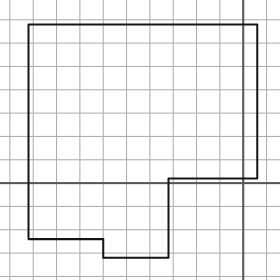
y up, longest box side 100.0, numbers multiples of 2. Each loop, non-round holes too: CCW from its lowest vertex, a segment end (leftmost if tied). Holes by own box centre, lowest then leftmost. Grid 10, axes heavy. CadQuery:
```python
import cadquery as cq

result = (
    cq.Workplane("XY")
    .moveTo(-60.0, -32.0)
    .lineTo(-32.0, -32.0)
    .lineTo(-32.0, 2.0)
    .lineTo(6.0, 2.0)
    .lineTo(6.0, 68.0)
    .lineTo(-92.0, 68.0)
    .lineTo(-92.0, -24.0)
    .lineTo(-60.0, -24.0)
    .close()
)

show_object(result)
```